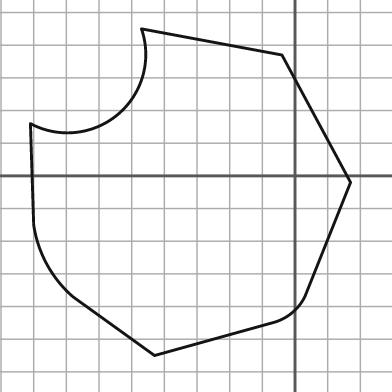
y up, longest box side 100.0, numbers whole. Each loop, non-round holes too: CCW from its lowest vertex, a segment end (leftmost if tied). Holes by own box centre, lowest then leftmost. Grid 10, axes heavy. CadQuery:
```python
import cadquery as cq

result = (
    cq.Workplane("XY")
    .moveTo(-43.0, -55.0)
    .lineTo(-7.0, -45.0)
    .threePointArc((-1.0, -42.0), (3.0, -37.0))
    .lineTo(17.0, -2.0)
    .lineTo(-4.0, 37.0)
    .lineTo(-47.0, 45.0)
    .threePointArc((-54.0, 19.0), (-81.0, 16.0))
    .lineTo(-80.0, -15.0)
    .threePointArc((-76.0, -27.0), (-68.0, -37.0))
    .close()
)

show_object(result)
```